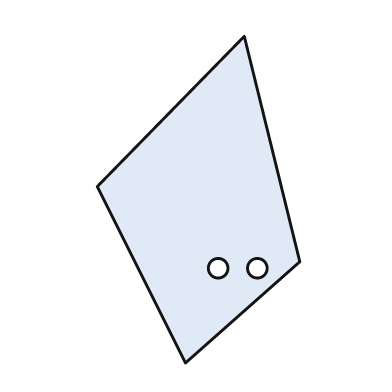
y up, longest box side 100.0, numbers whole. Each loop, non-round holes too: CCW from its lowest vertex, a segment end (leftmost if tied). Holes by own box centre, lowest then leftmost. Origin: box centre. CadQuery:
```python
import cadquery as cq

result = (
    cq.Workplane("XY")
    .moveTo(-4.0, -50.0)
    .lineTo(31.0, -19.0)
    .lineTo(14.0, 50.0)
    .lineTo(-31.0, 4.0)
    .close()
    .moveTo(6.0, -21.0)
    .circle(3.0)
    .moveTo(18.0, -21.0)
    .circle(3.0)
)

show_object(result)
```